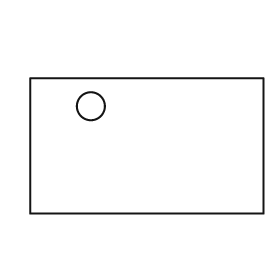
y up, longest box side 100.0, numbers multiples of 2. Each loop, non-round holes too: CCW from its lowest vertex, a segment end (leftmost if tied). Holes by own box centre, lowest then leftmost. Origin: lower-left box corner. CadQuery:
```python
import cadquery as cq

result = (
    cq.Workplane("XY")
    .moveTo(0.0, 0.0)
    .lineTo(100.0, 0.0)
    .lineTo(100.0, 58.0)
    .lineTo(0.0, 58.0)
    .close()
    .moveTo(26.0, 46.0)
    .circle(6.0)
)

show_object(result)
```